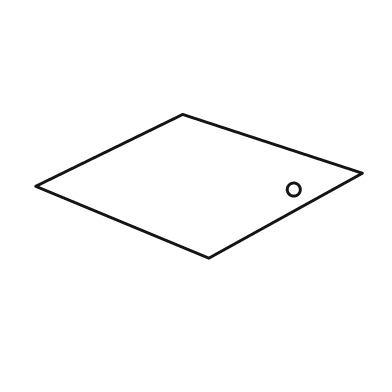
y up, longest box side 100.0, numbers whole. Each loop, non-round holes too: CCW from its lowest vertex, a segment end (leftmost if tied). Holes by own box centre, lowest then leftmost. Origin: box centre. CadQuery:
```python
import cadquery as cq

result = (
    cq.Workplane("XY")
    .moveTo(3.0, -22.0)
    .lineTo(50.0, 4.0)
    .lineTo(-5.0, 22.0)
    .lineTo(-50.0, 0.0)
    .close()
    .moveTo(29.0, -1.0)
    .circle(2.0)
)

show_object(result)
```